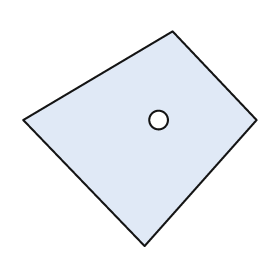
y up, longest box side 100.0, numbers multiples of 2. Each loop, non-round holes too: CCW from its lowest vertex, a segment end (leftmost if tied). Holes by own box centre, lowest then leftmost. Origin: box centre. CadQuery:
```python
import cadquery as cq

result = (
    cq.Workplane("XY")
    .moveTo(2.0, -46.0)
    .lineTo(50.0, 8.0)
    .lineTo(14.0, 46.0)
    .lineTo(-50.0, 8.0)
    .close()
    .moveTo(8.0, 8.0)
    .circle(4.0)
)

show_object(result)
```